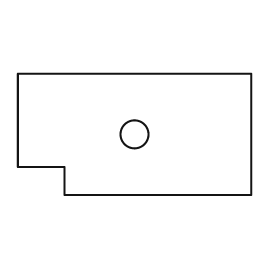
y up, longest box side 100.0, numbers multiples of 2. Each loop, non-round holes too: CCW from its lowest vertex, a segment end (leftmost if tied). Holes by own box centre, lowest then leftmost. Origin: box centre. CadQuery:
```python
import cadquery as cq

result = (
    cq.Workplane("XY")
    .moveTo(-30.0, -26.0)
    .lineTo(50.0, -26.0)
    .lineTo(50.0, 26.0)
    .lineTo(-50.0, 26.0)
    .lineTo(-50.0, -14.0)
    .lineTo(-30.0, -14.0)
    .close()
    .moveTo(0.0, 0.0)
    .circle(6.0)
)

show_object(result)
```